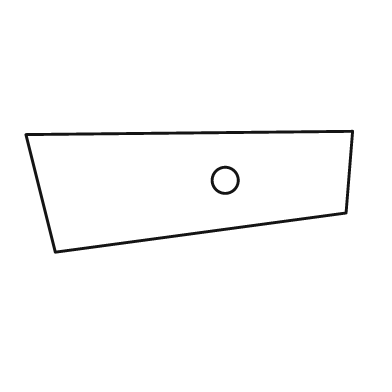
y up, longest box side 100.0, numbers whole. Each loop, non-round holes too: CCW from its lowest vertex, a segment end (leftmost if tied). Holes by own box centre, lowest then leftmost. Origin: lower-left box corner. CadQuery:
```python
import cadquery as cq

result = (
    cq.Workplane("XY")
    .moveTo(9.0, 0.0)
    .lineTo(98.0, 12.0)
    .lineTo(100.0, 37.0)
    .lineTo(0.0, 36.0)
    .close()
    .moveTo(61.0, 22.0)
    .circle(4.0)
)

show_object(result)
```